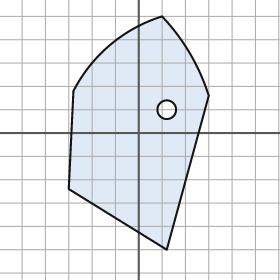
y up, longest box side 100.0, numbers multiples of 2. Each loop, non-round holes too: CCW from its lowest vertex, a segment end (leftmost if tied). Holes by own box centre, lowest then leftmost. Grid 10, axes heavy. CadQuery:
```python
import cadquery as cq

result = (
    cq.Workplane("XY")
    .moveTo(12.0, -50.0)
    .lineTo(30.0, 16.0)
    .threePointArc((22.0, 34.0), (10.0, 50.0))
    .threePointArc((-12.0, 38.0), (-28.0, 18.0))
    .lineTo(-30.0, -24.0)
    .close()
    .moveTo(12.0, 10.0)
    .circle(4.0)
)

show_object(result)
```